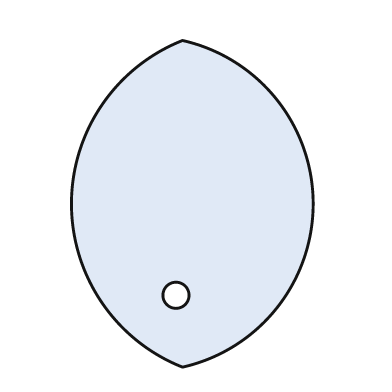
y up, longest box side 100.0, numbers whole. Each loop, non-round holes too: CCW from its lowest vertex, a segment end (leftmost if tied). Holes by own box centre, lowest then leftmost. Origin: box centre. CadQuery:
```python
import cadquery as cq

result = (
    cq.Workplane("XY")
    .moveTo(-3.0, -50.0)
    .threePointArc((37.0, 0.0), (-3.0, 50.0))
    .threePointArc((-37.0, 0.0), (-3.0, -50.0))
    .close()
    .moveTo(-5.0, -28.0)
    .circle(4.0)
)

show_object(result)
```